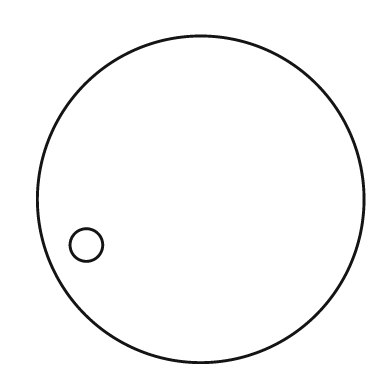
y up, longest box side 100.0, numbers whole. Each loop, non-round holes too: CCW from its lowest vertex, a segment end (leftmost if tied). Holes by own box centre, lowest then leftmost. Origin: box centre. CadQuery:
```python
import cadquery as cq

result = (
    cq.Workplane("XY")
    .moveTo(0.0, 0.0)
    .circle(50.0)
    .moveTo(-35.0, -14.0)
    .circle(5.0)
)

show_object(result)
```